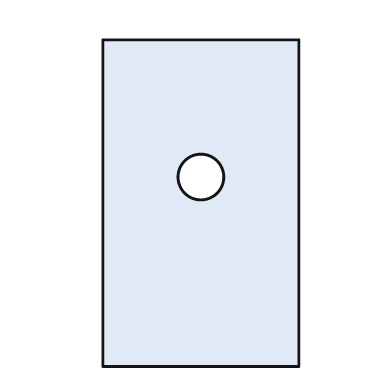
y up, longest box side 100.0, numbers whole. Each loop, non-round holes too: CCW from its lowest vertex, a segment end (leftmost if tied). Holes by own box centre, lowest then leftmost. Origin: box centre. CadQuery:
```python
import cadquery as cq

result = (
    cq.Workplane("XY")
    .moveTo(-30.0, -50.0)
    .lineTo(30.0, -50.0)
    .lineTo(30.0, 50.0)
    .lineTo(-30.0, 50.0)
    .close()
    .moveTo(0.0, 8.0)
    .circle(7.0)
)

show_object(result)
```